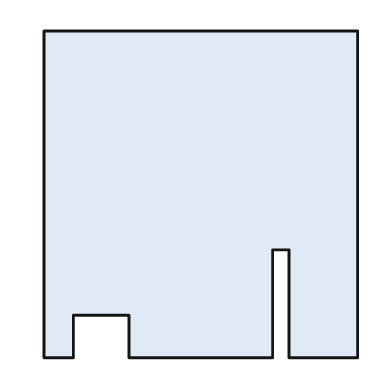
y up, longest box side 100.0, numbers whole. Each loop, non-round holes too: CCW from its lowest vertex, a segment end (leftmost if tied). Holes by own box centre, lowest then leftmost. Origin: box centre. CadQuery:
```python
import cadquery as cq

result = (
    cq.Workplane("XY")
    .moveTo(-48.0, -50.0)
    .lineTo(-39.0, -50.0)
    .lineTo(-39.0, -37.0)
    .lineTo(-22.0, -37.0)
    .lineTo(-22.0, -50.0)
    .lineTo(22.0, -50.0)
    .lineTo(22.0, -17.0)
    .lineTo(27.0, -17.0)
    .lineTo(27.0, -50.0)
    .lineTo(48.0, -50.0)
    .lineTo(48.0, 50.0)
    .lineTo(-48.0, 50.0)
    .close()
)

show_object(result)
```